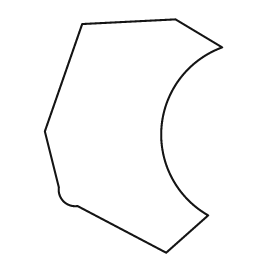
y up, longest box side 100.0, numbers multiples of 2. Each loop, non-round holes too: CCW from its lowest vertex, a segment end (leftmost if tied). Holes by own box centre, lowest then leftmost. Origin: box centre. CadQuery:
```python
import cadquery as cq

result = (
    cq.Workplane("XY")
    .moveTo(14.0, -50.0)
    .lineTo(32.0, -34.0)
    .threePointArc((12.0, 4.0), (38.0, 38.0))
    .lineTo(18.0, 50.0)
    .lineTo(-22.0, 48.0)
    .lineTo(-38.0, 2.0)
    .lineTo(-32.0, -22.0)
    .threePointArc((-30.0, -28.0), (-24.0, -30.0))
    .close()
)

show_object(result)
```